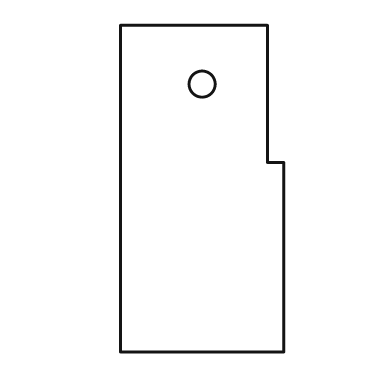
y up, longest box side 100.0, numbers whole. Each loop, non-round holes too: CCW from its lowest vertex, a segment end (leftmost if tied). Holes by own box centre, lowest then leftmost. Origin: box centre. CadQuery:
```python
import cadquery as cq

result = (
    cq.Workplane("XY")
    .moveTo(-25.0, -50.0)
    .lineTo(25.0, -50.0)
    .lineTo(25.0, 8.0)
    .lineTo(20.0, 8.0)
    .lineTo(20.0, 50.0)
    .lineTo(-25.0, 50.0)
    .close()
    .moveTo(0.0, 32.0)
    .circle(4.0)
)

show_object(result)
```